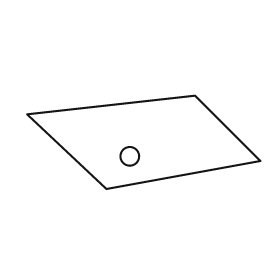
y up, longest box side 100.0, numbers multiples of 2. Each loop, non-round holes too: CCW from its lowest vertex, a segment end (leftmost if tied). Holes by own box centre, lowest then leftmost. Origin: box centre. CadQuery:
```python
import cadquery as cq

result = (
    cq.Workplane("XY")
    .moveTo(-16.0, -20.0)
    .lineTo(50.0, -8.0)
    .lineTo(22.0, 20.0)
    .lineTo(-50.0, 12.0)
    .close()
    .moveTo(-6.0, -6.0)
    .circle(4.0)
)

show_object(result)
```